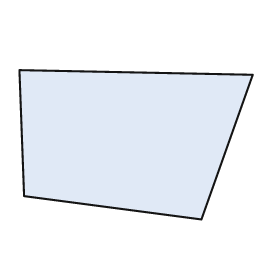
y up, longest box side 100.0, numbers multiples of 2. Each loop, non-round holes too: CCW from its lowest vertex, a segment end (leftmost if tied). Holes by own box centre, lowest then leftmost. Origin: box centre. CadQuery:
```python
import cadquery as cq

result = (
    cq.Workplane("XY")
    .moveTo(28.0, -32.0)
    .lineTo(50.0, 30.0)
    .lineTo(-50.0, 32.0)
    .lineTo(-48.0, -22.0)
    .close()
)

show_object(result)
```